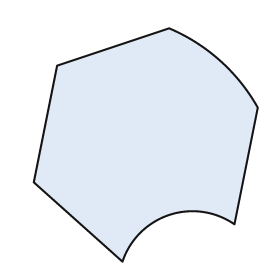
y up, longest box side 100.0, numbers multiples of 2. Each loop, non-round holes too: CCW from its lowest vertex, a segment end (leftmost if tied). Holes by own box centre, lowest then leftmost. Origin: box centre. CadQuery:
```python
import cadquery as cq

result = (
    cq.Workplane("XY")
    .moveTo(-10.0, -50.0)
    .threePointArc((10.0, -30.0), (38.0, -34.0))
    .lineTo(48.0, 16.0)
    .threePointArc((32.0, 36.0), (10.0, 50.0))
    .lineTo(-38.0, 34.0)
    .lineTo(-48.0, -16.0)
    .close()
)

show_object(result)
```